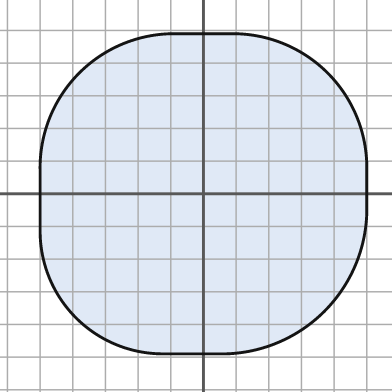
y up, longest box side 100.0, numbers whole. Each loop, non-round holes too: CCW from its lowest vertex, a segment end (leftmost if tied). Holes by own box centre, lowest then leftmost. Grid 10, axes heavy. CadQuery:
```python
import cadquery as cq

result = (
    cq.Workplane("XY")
    .moveTo(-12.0, -49.0)
    .lineTo(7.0, -49.0)
    .threePointArc((37.0, -36.0), (50.0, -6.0))
    .lineTo(50.0, 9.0)
    .threePointArc((38.0, 37.0), (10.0, 49.0))
    .lineTo(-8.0, 49.0)
    .threePointArc((-38.0, 37.0), (-50.0, 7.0))
    .lineTo(-50.0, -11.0)
    .threePointArc((-39.0, -38.0), (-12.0, -49.0))
    .close()
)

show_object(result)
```